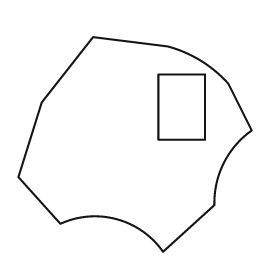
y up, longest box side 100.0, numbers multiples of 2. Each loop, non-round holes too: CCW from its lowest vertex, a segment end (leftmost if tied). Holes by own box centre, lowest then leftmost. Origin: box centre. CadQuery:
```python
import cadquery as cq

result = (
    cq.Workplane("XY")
    .moveTo(12.0, -46.0)
    .lineTo(34.0, -26.0)
    .threePointArc((38.0, -8.0), (50.0, 6.0))
    .lineTo(40.0, 26.0)
    .threePointArc((28.0, 36.0), (14.0, 42.0))
    .lineTo(-18.0, 46.0)
    .lineTo(-40.0, 18.0)
    .lineTo(-50.0, -14.0)
    .lineTo(-32.0, -34.0)
    .threePointArc((-8.0, -32.0), (12.0, -46.0))
    .close()
    .moveTo(10.0, 2.0)
    .lineTo(30.0, 2.0)
    .lineTo(30.0, 30.0)
    .lineTo(10.0, 30.0)
    .close()
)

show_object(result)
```